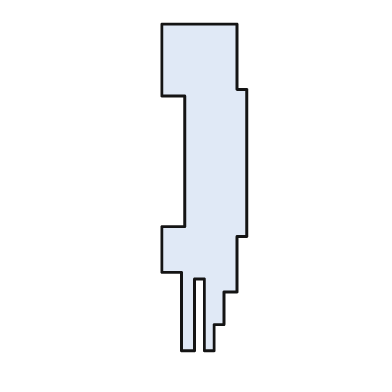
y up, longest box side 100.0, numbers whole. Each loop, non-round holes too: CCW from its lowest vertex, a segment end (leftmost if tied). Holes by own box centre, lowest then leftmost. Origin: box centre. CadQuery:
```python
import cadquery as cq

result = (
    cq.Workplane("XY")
    .moveTo(-7.0, -50.0)
    .lineTo(-3.0, -50.0)
    .lineTo(-3.0, -28.0)
    .lineTo(0.0, -28.0)
    .lineTo(0.0, -50.0)
    .lineTo(3.0, -50.0)
    .lineTo(3.0, -42.0)
    .lineTo(6.0, -42.0)
    .lineTo(6.0, -32.0)
    .lineTo(10.0, -32.0)
    .lineTo(10.0, -15.0)
    .lineTo(13.0, -15.0)
    .lineTo(13.0, 30.0)
    .lineTo(10.0, 30.0)
    .lineTo(10.0, 50.0)
    .lineTo(-13.0, 50.0)
    .lineTo(-13.0, 28.0)
    .lineTo(-6.0, 28.0)
    .lineTo(-6.0, -12.0)
    .lineTo(-13.0, -12.0)
    .lineTo(-13.0, -26.0)
    .lineTo(-7.0, -26.0)
    .close()
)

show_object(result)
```